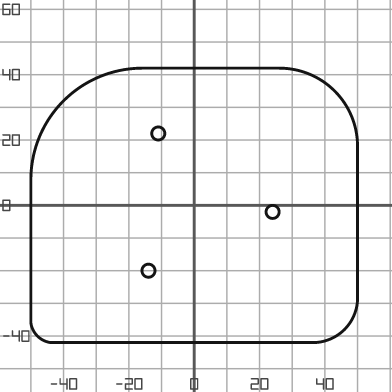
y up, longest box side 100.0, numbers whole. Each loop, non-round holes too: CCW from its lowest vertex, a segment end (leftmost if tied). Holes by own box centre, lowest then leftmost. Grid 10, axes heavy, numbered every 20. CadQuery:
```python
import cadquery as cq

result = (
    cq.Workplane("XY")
    .moveTo(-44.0, -42.0)
    .lineTo(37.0, -42.0)
    .threePointArc((46.0, -38.0), (50.0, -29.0))
    .lineTo(50.0, 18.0)
    .threePointArc((43.0, 35.0), (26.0, 42.0))
    .lineTo(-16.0, 42.0)
    .threePointArc((-40.0, 32.0), (-50.0, 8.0))
    .lineTo(-50.0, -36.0)
    .threePointArc((-48.0, -40.0), (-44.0, -42.0))
    .close()
    .moveTo(-14.0, -20.0)
    .circle(2.0)
    .moveTo(24.0, -2.0)
    .circle(2.0)
    .moveTo(-11.0, 22.0)
    .circle(2.0)
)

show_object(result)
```